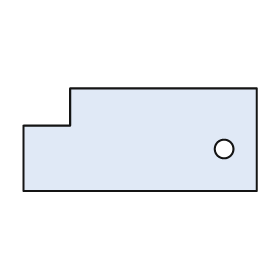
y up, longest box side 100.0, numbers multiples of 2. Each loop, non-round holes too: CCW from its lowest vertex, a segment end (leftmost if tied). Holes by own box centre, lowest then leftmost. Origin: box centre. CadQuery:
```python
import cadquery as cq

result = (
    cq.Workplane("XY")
    .moveTo(-50.0, -22.0)
    .lineTo(50.0, -22.0)
    .lineTo(50.0, 22.0)
    .lineTo(-30.0, 22.0)
    .lineTo(-30.0, 6.0)
    .lineTo(-50.0, 6.0)
    .close()
    .moveTo(36.0, -4.0)
    .circle(4.0)
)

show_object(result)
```